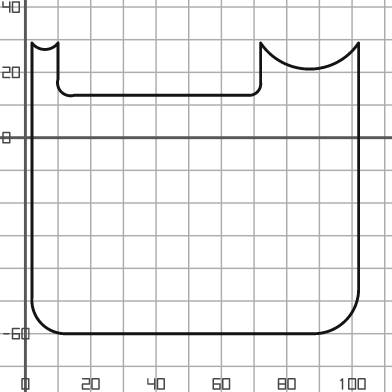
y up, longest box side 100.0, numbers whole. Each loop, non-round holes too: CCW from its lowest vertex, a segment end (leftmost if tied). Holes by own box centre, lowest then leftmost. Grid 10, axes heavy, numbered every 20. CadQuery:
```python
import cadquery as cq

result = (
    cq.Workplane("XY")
    .moveTo(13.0, -60.0)
    .lineTo(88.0, -60.0)
    .threePointArc((98.0, -56.0), (102.0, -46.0))
    .lineTo(102.0, 29.0)
    .threePointArc((87.0, 21.0), (72.0, 29.0))
    .lineTo(72.0, 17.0)
    .threePointArc((71.0, 14.0), (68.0, 13.0))
    .lineTo(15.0, 13.0)
    .threePointArc((11.0, 14.0), (10.0, 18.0))
    .lineTo(10.0, 29.0)
    .threePointArc((6.0, 27.0), (2.0, 29.0))
    .lineTo(2.0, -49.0)
    .threePointArc((5.0, -57.0), (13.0, -60.0))
    .close()
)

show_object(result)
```